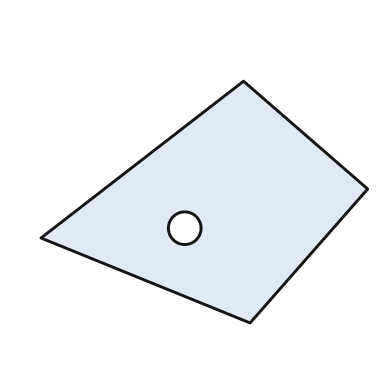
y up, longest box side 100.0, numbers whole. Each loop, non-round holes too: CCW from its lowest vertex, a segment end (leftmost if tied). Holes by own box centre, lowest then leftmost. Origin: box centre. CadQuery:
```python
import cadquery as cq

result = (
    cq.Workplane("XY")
    .moveTo(14.0, -37.0)
    .lineTo(50.0, 4.0)
    .lineTo(12.0, 37.0)
    .lineTo(-50.0, -11.0)
    .close()
    .moveTo(-6.0, -8.0)
    .circle(5.0)
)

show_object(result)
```